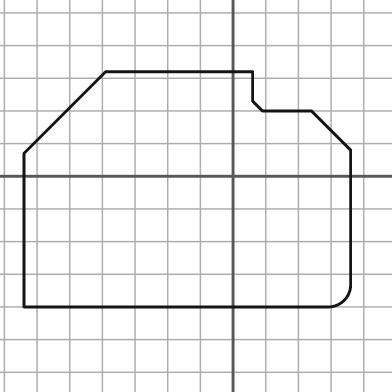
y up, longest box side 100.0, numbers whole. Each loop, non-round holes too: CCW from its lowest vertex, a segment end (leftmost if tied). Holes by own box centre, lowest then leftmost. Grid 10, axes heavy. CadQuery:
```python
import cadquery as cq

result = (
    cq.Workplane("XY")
    .moveTo(-64.0, -40.0)
    .lineTo(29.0, -40.0)
    .threePointArc((34.0, -38.0), (36.0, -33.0))
    .lineTo(36.0, 8.0)
    .lineTo(24.0, 20.0)
    .lineTo(9.0, 20.0)
    .lineTo(6.0, 23.0)
    .lineTo(6.0, 32.0)
    .lineTo(-39.0, 32.0)
    .lineTo(-64.0, 7.0)
    .close()
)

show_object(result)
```